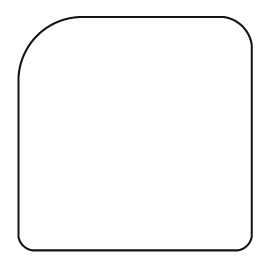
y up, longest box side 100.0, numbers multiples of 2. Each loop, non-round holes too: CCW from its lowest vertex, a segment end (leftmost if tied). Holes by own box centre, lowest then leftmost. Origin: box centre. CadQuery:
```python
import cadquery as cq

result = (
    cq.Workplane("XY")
    .moveTo(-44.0, -50.0)
    .lineTo(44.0, -50.0)
    .threePointArc((48.0, -48.0), (50.0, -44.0))
    .lineTo(50.0, 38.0)
    .threePointArc((46.0, 46.0), (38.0, 50.0))
    .lineTo(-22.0, 50.0)
    .threePointArc((-42.0, 42.0), (-50.0, 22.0))
    .lineTo(-50.0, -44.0)
    .threePointArc((-48.0, -48.0), (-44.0, -50.0))
    .close()
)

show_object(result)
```